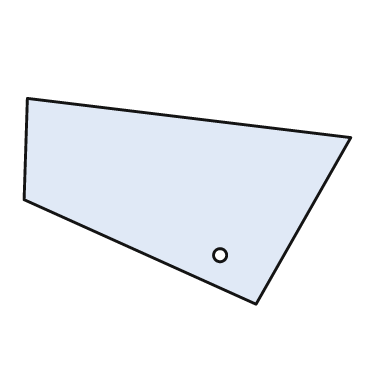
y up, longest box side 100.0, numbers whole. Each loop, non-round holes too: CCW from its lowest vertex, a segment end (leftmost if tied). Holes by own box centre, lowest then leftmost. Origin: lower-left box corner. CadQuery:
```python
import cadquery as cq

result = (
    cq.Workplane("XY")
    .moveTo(71.0, 0.0)
    .lineTo(100.0, 51.0)
    .lineTo(1.0, 63.0)
    .lineTo(0.0, 32.0)
    .close()
    .moveTo(60.0, 15.0)
    .circle(2.0)
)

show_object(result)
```